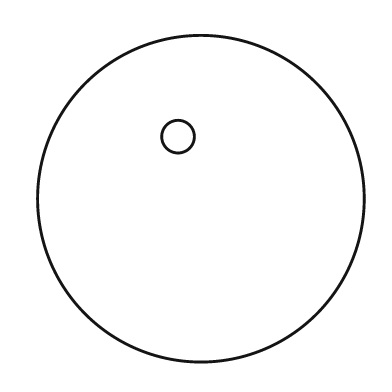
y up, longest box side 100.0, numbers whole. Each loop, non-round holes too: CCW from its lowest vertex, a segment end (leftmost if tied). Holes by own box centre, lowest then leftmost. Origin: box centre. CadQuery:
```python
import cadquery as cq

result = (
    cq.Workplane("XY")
    .moveTo(0.0, 0.0)
    .circle(50.0)
    .moveTo(-7.0, 19.0)
    .circle(5.0)
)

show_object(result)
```